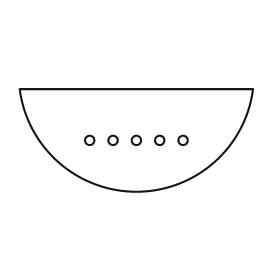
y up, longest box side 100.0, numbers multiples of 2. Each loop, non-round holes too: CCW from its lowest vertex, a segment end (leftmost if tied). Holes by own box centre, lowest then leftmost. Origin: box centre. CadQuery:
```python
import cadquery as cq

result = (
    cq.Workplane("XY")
    .moveTo(-50.0, 22.0)
    .threePointArc((0.0, -22.0), (50.0, 22.0))
    .close()
    .moveTo(-20.0, 0.0)
    .circle(2.0)
    .moveTo(-10.0, 0.0)
    .circle(2.0)
    .moveTo(0.0, 0.0)
    .circle(2.0)
    .moveTo(10.0, 0.0)
    .circle(2.0)
    .moveTo(20.0, 0.0)
    .circle(2.0)
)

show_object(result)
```